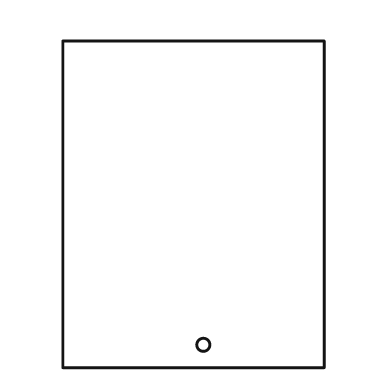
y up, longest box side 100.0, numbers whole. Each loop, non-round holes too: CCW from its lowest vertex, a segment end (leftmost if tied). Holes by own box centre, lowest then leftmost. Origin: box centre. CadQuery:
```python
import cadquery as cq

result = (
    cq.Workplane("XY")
    .moveTo(-40.0, -50.0)
    .lineTo(40.0, -50.0)
    .lineTo(40.0, 50.0)
    .lineTo(-40.0, 50.0)
    .close()
    .moveTo(3.0, -43.0)
    .circle(2.0)
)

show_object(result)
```